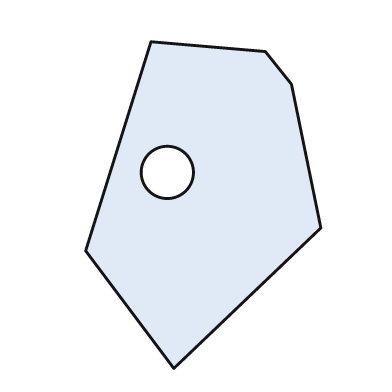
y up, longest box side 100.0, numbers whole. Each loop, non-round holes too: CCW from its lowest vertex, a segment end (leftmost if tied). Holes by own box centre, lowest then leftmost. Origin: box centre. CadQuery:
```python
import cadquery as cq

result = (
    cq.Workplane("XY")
    .moveTo(-9.0, -50.0)
    .lineTo(36.0, -7.0)
    .lineTo(27.0, 37.0)
    .lineTo(19.0, 47.0)
    .lineTo(-16.0, 50.0)
    .lineTo(-36.0, -14.0)
    .close()
    .moveTo(-11.0, 10.0)
    .circle(8.0)
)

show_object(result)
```